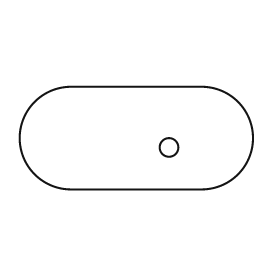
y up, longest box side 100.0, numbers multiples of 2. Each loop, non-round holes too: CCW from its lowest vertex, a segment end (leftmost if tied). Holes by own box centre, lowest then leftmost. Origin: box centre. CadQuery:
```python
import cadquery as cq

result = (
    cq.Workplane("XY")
    .moveTo(-28.0, -22.0)
    .lineTo(28.0, -22.0)
    .threePointArc((50.0, 0.0), (28.0, 22.0))
    .lineTo(-28.0, 22.0)
    .threePointArc((-50.0, 0.0), (-28.0, -22.0))
    .close()
    .moveTo(14.0, -4.0)
    .circle(4.0)
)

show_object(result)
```